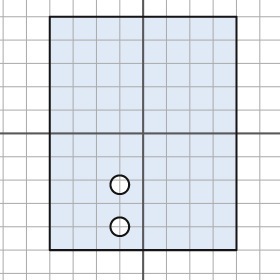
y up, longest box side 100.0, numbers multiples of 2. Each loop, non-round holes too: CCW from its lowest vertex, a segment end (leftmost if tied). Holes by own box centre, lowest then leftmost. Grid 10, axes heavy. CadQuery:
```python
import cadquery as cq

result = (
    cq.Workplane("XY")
    .moveTo(-40.0, -50.0)
    .lineTo(40.0, -50.0)
    .lineTo(40.0, 50.0)
    .lineTo(-40.0, 50.0)
    .close()
    .moveTo(-10.0, -40.0)
    .circle(4.0)
    .moveTo(-10.0, -22.0)
    .circle(4.0)
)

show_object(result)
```